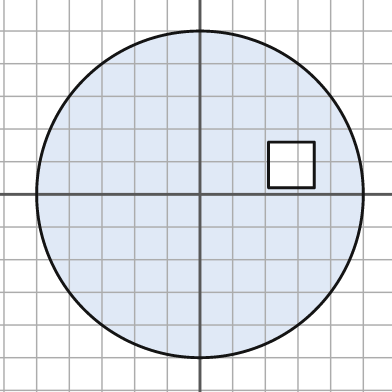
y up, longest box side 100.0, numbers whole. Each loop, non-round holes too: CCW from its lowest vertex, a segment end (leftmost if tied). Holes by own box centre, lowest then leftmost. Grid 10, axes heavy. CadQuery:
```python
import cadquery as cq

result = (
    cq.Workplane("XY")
    .moveTo(0.0, 0.0)
    .circle(50.0)
    .moveTo(21.0, 2.0)
    .lineTo(35.0, 2.0)
    .lineTo(35.0, 16.0)
    .lineTo(21.0, 16.0)
    .close()
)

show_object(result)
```